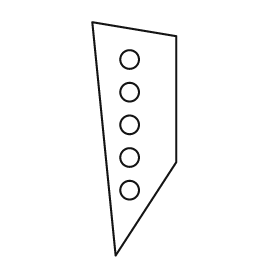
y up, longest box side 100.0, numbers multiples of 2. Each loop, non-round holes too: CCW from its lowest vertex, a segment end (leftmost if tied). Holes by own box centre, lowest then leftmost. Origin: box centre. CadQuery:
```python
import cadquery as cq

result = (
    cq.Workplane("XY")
    .moveTo(-8.0, -50.0)
    .lineTo(18.0, -10.0)
    .lineTo(18.0, 44.0)
    .lineTo(-18.0, 50.0)
    .close()
    .moveTo(-2.0, -22.0)
    .circle(4.0)
    .moveTo(-2.0, -8.0)
    .circle(4.0)
    .moveTo(-2.0, 6.0)
    .circle(4.0)
    .moveTo(-2.0, 20.0)
    .circle(4.0)
    .moveTo(-2.0, 34.0)
    .circle(4.0)
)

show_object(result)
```